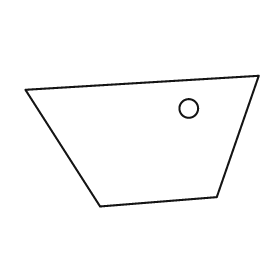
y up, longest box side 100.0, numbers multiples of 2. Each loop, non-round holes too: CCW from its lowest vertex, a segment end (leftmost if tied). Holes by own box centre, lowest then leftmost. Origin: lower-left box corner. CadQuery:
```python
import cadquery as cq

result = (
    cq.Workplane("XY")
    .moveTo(32.0, 0.0)
    .lineTo(82.0, 4.0)
    .lineTo(100.0, 56.0)
    .lineTo(0.0, 50.0)
    .close()
    .moveTo(70.0, 42.0)
    .circle(4.0)
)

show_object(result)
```